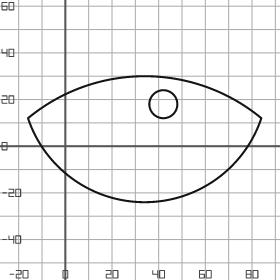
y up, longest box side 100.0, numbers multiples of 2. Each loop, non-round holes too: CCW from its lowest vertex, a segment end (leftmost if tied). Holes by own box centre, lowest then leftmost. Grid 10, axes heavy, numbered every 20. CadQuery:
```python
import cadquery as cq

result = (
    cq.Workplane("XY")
    .moveTo(-16.0, 12.0)
    .threePointArc((34.0, -24.0), (84.0, 12.0))
    .threePointArc((34.0, 30.0), (-16.0, 12.0))
    .close()
    .moveTo(42.0, 18.0)
    .circle(6.0)
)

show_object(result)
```